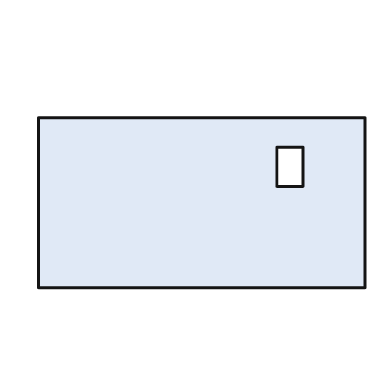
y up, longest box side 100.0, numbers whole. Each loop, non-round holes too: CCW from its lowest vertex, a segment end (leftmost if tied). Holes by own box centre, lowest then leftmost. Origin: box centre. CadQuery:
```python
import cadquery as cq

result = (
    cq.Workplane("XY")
    .moveTo(-50.0, -26.0)
    .lineTo(50.0, -26.0)
    .lineTo(50.0, 26.0)
    .lineTo(-50.0, 26.0)
    .close()
    .moveTo(23.0, 5.0)
    .lineTo(31.0, 5.0)
    .lineTo(31.0, 17.0)
    .lineTo(23.0, 17.0)
    .close()
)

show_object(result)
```